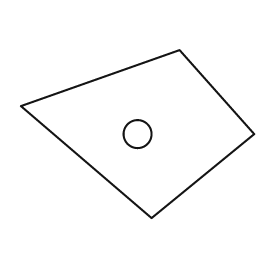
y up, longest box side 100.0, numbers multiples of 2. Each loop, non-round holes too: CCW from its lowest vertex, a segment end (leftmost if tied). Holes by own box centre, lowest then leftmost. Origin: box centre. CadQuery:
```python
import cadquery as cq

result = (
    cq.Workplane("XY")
    .moveTo(6.0, -36.0)
    .lineTo(50.0, 0.0)
    .lineTo(18.0, 36.0)
    .lineTo(-50.0, 12.0)
    .close()
    .moveTo(0.0, 0.0)
    .circle(6.0)
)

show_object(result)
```